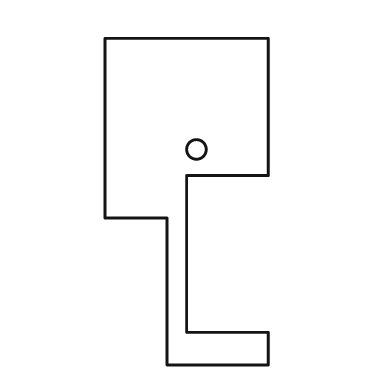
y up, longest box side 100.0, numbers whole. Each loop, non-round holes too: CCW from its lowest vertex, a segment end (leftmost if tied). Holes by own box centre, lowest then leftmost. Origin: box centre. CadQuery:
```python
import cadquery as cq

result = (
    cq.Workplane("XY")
    .moveTo(-6.0, -50.0)
    .lineTo(25.0, -50.0)
    .lineTo(25.0, -40.0)
    .lineTo(0.0, -40.0)
    .lineTo(0.0, 8.0)
    .lineTo(25.0, 8.0)
    .lineTo(25.0, 50.0)
    .lineTo(-25.0, 50.0)
    .lineTo(-25.0, -5.0)
    .lineTo(-6.0, -5.0)
    .close()
    .moveTo(3.0, 16.0)
    .circle(3.0)
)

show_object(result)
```